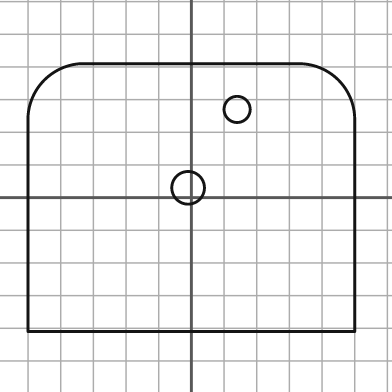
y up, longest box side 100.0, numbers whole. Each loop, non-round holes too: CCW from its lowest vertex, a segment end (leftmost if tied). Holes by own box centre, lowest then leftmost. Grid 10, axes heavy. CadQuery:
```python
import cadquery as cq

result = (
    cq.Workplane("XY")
    .moveTo(-50.0, -41.0)
    .lineTo(50.0, -41.0)
    .lineTo(50.0, 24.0)
    .threePointArc((45.0, 36.0), (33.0, 41.0))
    .lineTo(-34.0, 41.0)
    .threePointArc((-45.0, 36.0), (-50.0, 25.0))
    .close()
    .moveTo(-1.0, 3.0)
    .circle(5.0)
    .moveTo(14.0, 27.0)
    .circle(4.0)
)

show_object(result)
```